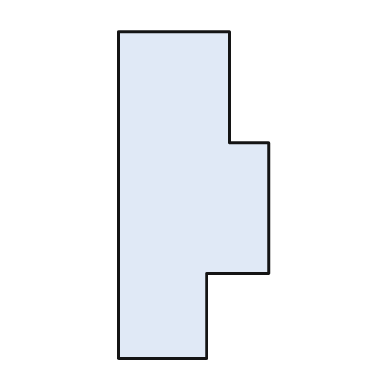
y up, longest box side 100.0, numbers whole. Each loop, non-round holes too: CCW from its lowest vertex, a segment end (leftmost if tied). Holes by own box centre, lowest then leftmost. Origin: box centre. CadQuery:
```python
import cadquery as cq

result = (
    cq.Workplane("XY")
    .moveTo(-23.0, -50.0)
    .lineTo(4.0, -50.0)
    .lineTo(4.0, -24.0)
    .lineTo(23.0, -24.0)
    .lineTo(23.0, 16.0)
    .lineTo(11.0, 16.0)
    .lineTo(11.0, 50.0)
    .lineTo(-23.0, 50.0)
    .close()
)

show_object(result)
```